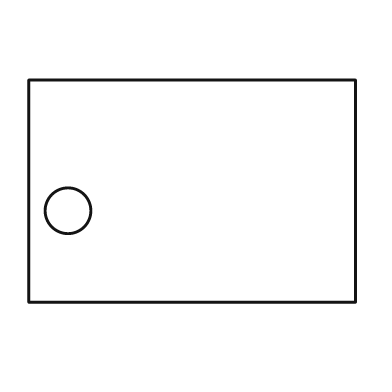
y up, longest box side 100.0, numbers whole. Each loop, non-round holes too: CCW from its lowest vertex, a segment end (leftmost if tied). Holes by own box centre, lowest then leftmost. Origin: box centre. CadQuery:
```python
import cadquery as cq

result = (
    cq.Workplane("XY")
    .moveTo(-50.0, -34.0)
    .lineTo(50.0, -34.0)
    .lineTo(50.0, 34.0)
    .lineTo(-50.0, 34.0)
    .close()
    .moveTo(-38.0, -6.0)
    .circle(7.0)
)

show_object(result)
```